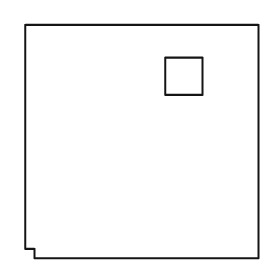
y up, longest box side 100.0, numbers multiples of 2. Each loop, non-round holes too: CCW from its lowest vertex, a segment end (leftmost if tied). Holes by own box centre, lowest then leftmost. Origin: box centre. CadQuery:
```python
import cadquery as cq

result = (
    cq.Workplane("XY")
    .moveTo(-46.0, -50.0)
    .lineTo(50.0, -50.0)
    .lineTo(50.0, 50.0)
    .lineTo(-50.0, 50.0)
    .lineTo(-50.0, -46.0)
    .lineTo(-46.0, -46.0)
    .close()
    .moveTo(10.0, 20.0)
    .lineTo(26.0, 20.0)
    .lineTo(26.0, 36.0)
    .lineTo(10.0, 36.0)
    .close()
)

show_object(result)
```